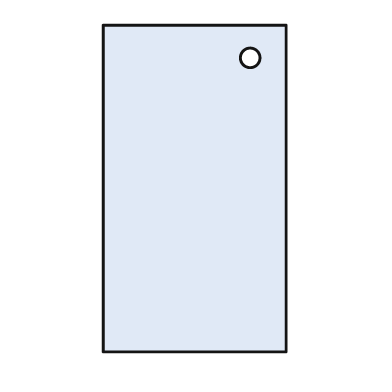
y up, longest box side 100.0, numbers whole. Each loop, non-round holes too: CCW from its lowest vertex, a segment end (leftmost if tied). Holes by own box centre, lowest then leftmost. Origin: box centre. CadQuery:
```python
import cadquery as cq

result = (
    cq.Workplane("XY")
    .moveTo(-28.0, -50.0)
    .lineTo(28.0, -50.0)
    .lineTo(28.0, 50.0)
    .lineTo(-28.0, 50.0)
    .close()
    .moveTo(17.0, 40.0)
    .circle(3.0)
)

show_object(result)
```